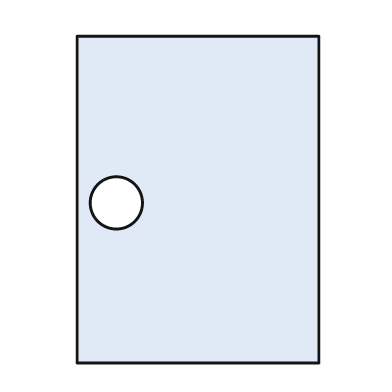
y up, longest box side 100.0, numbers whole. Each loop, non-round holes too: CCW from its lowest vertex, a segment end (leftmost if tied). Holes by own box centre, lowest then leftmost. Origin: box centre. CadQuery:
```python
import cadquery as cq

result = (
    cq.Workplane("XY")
    .moveTo(-37.0, -50.0)
    .lineTo(37.0, -50.0)
    .lineTo(37.0, 50.0)
    .lineTo(-37.0, 50.0)
    .close()
    .moveTo(-25.0, -1.0)
    .circle(8.0)
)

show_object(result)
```